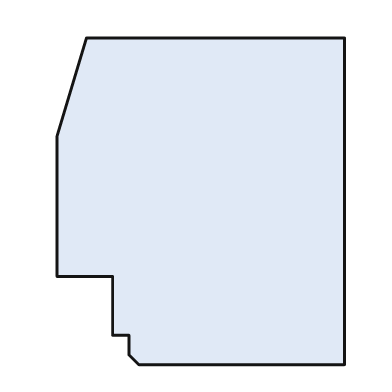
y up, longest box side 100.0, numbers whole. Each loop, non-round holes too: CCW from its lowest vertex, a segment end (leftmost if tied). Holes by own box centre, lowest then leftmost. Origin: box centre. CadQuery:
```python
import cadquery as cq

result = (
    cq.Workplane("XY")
    .moveTo(-19.0, -50.0)
    .lineTo(44.0, -50.0)
    .lineTo(44.0, 50.0)
    .lineTo(-35.0, 50.0)
    .lineTo(-44.0, 20.0)
    .lineTo(-44.0, -23.0)
    .lineTo(-27.0, -23.0)
    .lineTo(-27.0, -41.0)
    .lineTo(-22.0, -41.0)
    .lineTo(-22.0, -47.0)
    .close()
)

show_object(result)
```